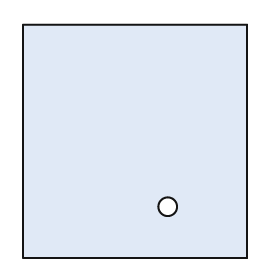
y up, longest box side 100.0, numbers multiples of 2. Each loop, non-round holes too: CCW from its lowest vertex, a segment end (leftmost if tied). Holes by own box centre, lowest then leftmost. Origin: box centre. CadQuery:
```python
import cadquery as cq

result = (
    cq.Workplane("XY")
    .moveTo(-48.0, -50.0)
    .lineTo(48.0, -50.0)
    .lineTo(48.0, 50.0)
    .lineTo(-48.0, 50.0)
    .close()
    .moveTo(14.0, -28.0)
    .circle(4.0)
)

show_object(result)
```